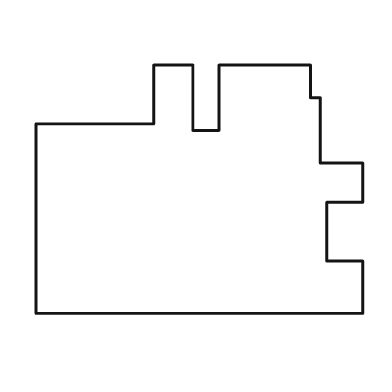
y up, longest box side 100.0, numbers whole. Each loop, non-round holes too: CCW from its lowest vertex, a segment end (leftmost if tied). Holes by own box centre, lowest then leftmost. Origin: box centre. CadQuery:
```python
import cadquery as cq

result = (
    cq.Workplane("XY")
    .moveTo(-50.0, -38.0)
    .lineTo(50.0, -38.0)
    .lineTo(50.0, -22.0)
    .lineTo(39.0, -22.0)
    .lineTo(39.0, -4.0)
    .lineTo(50.0, -4.0)
    .lineTo(50.0, 8.0)
    .lineTo(37.0, 8.0)
    .lineTo(37.0, 28.0)
    .lineTo(34.0, 28.0)
    .lineTo(34.0, 38.0)
    .lineTo(6.0, 38.0)
    .lineTo(6.0, 18.0)
    .lineTo(-2.0, 18.0)
    .lineTo(-2.0, 38.0)
    .lineTo(-14.0, 38.0)
    .lineTo(-14.0, 20.0)
    .lineTo(-50.0, 20.0)
    .close()
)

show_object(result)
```